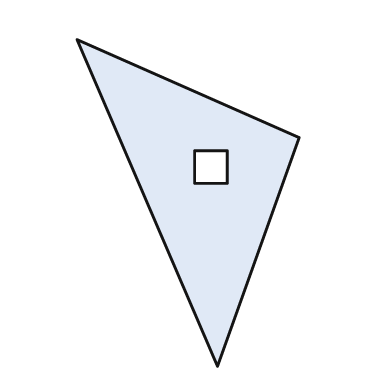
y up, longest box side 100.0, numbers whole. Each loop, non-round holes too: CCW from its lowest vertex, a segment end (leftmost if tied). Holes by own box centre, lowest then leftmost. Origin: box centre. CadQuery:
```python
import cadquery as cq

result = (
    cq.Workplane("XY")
    .moveTo(9.0, -50.0)
    .lineTo(34.0, 20.0)
    .lineTo(-34.0, 50.0)
    .close()
    .moveTo(2.0, 6.0)
    .lineTo(12.0, 6.0)
    .lineTo(12.0, 16.0)
    .lineTo(2.0, 16.0)
    .close()
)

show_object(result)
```